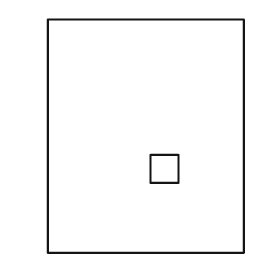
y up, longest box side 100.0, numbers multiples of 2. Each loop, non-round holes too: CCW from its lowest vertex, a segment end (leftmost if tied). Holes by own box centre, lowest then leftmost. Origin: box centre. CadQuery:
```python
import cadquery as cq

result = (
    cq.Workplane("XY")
    .moveTo(-42.0, -50.0)
    .lineTo(42.0, -50.0)
    .lineTo(42.0, 50.0)
    .lineTo(-42.0, 50.0)
    .close()
    .moveTo(2.0, -20.0)
    .lineTo(14.0, -20.0)
    .lineTo(14.0, -8.0)
    .lineTo(2.0, -8.0)
    .close()
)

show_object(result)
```